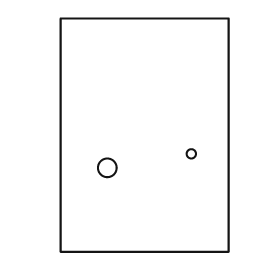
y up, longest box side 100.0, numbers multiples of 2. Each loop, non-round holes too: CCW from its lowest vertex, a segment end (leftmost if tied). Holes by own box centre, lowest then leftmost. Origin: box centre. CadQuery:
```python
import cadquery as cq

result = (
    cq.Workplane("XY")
    .moveTo(-36.0, -50.0)
    .lineTo(36.0, -50.0)
    .lineTo(36.0, 50.0)
    .lineTo(-36.0, 50.0)
    .close()
    .moveTo(-16.0, -14.0)
    .circle(4.0)
    .moveTo(20.0, -8.0)
    .circle(2.0)
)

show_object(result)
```